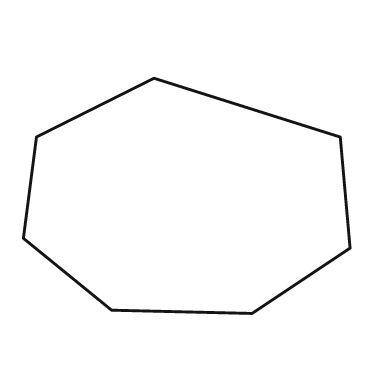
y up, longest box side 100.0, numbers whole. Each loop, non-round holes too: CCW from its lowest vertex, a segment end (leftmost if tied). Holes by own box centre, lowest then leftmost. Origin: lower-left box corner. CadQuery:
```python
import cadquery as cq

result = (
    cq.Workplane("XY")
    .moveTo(70.0, 0.0)
    .lineTo(100.0, 20.0)
    .lineTo(97.0, 54.0)
    .lineTo(40.0, 72.0)
    .lineTo(4.0, 54.0)
    .lineTo(0.0, 23.0)
    .lineTo(27.0, 1.0)
    .close()
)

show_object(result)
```